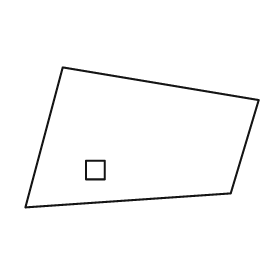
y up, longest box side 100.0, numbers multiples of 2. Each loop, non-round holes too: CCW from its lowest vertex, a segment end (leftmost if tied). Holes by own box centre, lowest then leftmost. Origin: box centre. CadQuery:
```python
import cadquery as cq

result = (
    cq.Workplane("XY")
    .moveTo(-50.0, -30.0)
    .lineTo(38.0, -24.0)
    .lineTo(50.0, 16.0)
    .lineTo(-34.0, 30.0)
    .close()
    .moveTo(-24.0, -18.0)
    .lineTo(-16.0, -18.0)
    .lineTo(-16.0, -10.0)
    .lineTo(-24.0, -10.0)
    .close()
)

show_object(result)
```